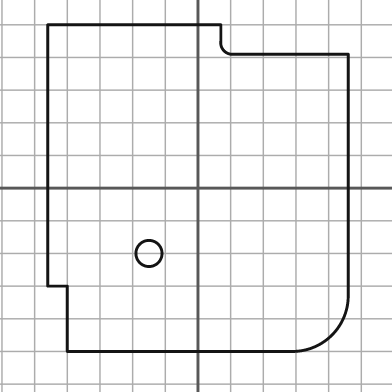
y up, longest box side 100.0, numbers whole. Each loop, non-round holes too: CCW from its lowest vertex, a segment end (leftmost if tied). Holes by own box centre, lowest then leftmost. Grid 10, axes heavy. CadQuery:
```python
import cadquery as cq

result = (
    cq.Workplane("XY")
    .moveTo(-40.0, -50.0)
    .lineTo(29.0, -50.0)
    .threePointArc((41.0, -45.0), (46.0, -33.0))
    .lineTo(46.0, 41.0)
    .lineTo(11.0, 41.0)
    .threePointArc((8.0, 42.0), (7.0, 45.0))
    .lineTo(7.0, 50.0)
    .lineTo(-46.0, 50.0)
    .lineTo(-46.0, -30.0)
    .lineTo(-40.0, -30.0)
    .close()
    .moveTo(-15.0, -20.0)
    .circle(4.0)
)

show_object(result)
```